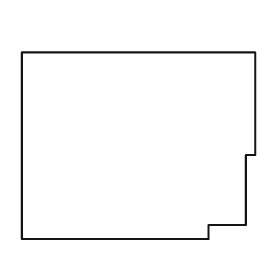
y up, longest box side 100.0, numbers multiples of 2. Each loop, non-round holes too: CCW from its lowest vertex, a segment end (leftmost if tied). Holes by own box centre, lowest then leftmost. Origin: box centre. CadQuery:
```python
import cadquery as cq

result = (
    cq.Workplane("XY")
    .moveTo(-50.0, -40.0)
    .lineTo(30.0, -40.0)
    .lineTo(30.0, -34.0)
    .lineTo(46.0, -34.0)
    .lineTo(46.0, -4.0)
    .lineTo(50.0, -4.0)
    .lineTo(50.0, 40.0)
    .lineTo(-50.0, 40.0)
    .close()
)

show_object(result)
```